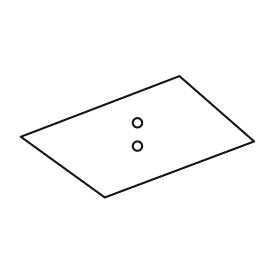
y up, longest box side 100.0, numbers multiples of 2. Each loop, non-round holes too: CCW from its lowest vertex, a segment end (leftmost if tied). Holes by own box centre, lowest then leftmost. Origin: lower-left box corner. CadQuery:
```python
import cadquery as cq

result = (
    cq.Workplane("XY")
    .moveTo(36.0, 0.0)
    .lineTo(100.0, 24.0)
    .lineTo(68.0, 52.0)
    .lineTo(0.0, 26.0)
    .close()
    .moveTo(50.0, 22.0)
    .circle(2.0)
    .moveTo(50.0, 32.0)
    .circle(2.0)
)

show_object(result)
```